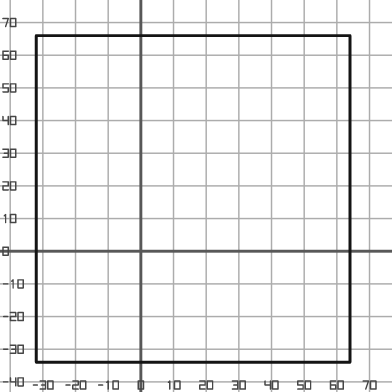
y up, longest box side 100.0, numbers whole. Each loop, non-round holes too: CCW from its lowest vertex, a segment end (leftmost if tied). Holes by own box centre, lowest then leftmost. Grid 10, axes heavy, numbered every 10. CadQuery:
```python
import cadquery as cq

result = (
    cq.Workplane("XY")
    .moveTo(-32.0, -34.0)
    .lineTo(64.0, -34.0)
    .lineTo(64.0, 66.0)
    .lineTo(-32.0, 66.0)
    .close()
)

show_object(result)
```